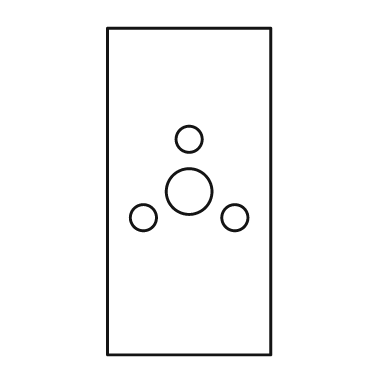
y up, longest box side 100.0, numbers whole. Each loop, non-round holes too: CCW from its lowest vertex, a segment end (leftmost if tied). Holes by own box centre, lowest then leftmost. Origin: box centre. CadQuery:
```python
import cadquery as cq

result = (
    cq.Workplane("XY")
    .moveTo(-25.0, -50.0)
    .lineTo(25.0, -50.0)
    .lineTo(25.0, 50.0)
    .lineTo(-25.0, 50.0)
    .close()
    .moveTo(-14.0, -8.0)
    .circle(4.0)
    .moveTo(14.0, -8.0)
    .circle(4.0)
    .moveTo(0.0, 0.0)
    .circle(7.0)
    .moveTo(0.0, 16.0)
    .circle(4.0)
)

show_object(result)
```